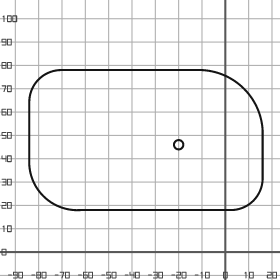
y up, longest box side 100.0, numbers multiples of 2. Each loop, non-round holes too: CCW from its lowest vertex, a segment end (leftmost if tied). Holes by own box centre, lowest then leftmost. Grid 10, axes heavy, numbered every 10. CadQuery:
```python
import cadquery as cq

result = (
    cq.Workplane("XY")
    .moveTo(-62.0, 18.0)
    .lineTo(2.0, 18.0)
    .threePointArc((12.0, 22.0), (16.0, 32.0))
    .lineTo(16.0, 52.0)
    .threePointArc((8.0, 70.0), (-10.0, 78.0))
    .lineTo(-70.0, 78.0)
    .threePointArc((-80.0, 74.0), (-84.0, 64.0))
    .lineTo(-84.0, 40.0)
    .threePointArc((-78.0, 24.0), (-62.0, 18.0))
    .close()
    .moveTo(-20.0, 46.0)
    .circle(2.0)
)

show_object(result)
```